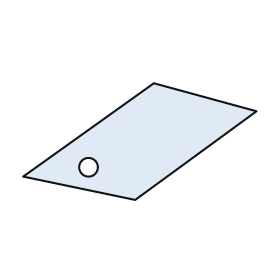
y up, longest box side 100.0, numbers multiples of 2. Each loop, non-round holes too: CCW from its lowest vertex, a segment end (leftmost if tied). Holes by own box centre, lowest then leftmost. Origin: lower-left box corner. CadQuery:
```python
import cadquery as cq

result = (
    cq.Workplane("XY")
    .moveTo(48.0, 0.0)
    .lineTo(100.0, 38.0)
    .lineTo(56.0, 50.0)
    .lineTo(0.0, 10.0)
    .close()
    .moveTo(28.0, 14.0)
    .circle(4.0)
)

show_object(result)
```